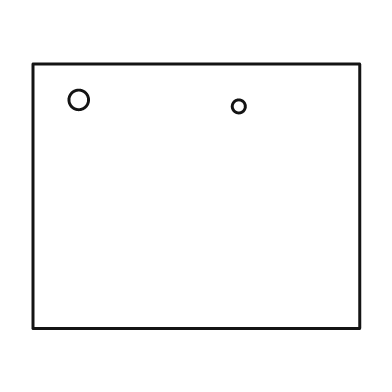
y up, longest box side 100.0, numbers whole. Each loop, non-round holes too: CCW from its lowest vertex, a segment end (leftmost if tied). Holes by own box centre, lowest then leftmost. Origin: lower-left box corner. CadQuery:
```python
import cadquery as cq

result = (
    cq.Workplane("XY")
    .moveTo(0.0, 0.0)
    .lineTo(100.0, 0.0)
    .lineTo(100.0, 81.0)
    .lineTo(0.0, 81.0)
    .close()
    .moveTo(63.0, 68.0)
    .circle(2.0)
    .moveTo(14.0, 70.0)
    .circle(3.0)
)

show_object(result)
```